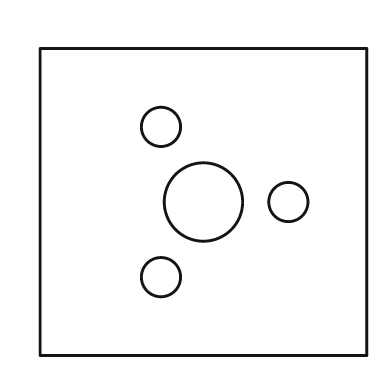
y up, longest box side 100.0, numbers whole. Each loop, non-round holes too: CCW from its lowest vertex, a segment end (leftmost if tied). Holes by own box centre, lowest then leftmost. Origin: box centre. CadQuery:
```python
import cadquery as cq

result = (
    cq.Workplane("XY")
    .moveTo(-50.0, -47.0)
    .lineTo(50.0, -47.0)
    .lineTo(50.0, 47.0)
    .lineTo(-50.0, 47.0)
    .close()
    .moveTo(-13.0, -23.0)
    .circle(6.0)
    .moveTo(0.0, 0.0)
    .circle(12.0)
    .moveTo(26.0, 0.0)
    .circle(6.0)
    .moveTo(-13.0, 23.0)
    .circle(6.0)
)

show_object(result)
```